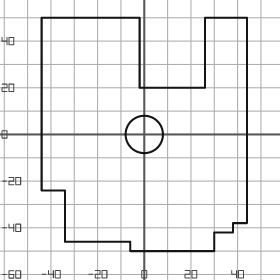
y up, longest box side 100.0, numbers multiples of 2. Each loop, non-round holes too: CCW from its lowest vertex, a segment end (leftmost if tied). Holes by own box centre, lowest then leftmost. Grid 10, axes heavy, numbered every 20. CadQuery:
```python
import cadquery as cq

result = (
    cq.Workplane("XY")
    .moveTo(-6.0, -50.0)
    .lineTo(30.0, -50.0)
    .lineTo(30.0, -42.0)
    .lineTo(38.0, -42.0)
    .lineTo(38.0, -38.0)
    .lineTo(44.0, -38.0)
    .lineTo(44.0, 50.0)
    .lineTo(26.0, 50.0)
    .lineTo(26.0, 20.0)
    .lineTo(-2.0, 20.0)
    .lineTo(-2.0, 50.0)
    .lineTo(-44.0, 50.0)
    .lineTo(-44.0, -24.0)
    .lineTo(-34.0, -24.0)
    .lineTo(-34.0, -46.0)
    .lineTo(-6.0, -46.0)
    .close()
    .moveTo(0.0, 0.0)
    .circle(8.0)
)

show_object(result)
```